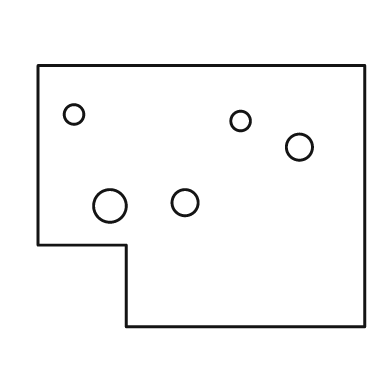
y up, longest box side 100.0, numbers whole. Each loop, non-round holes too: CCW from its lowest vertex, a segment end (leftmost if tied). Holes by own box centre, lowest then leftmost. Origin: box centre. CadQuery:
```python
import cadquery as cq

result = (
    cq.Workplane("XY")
    .moveTo(-23.0, -40.0)
    .lineTo(50.0, -40.0)
    .lineTo(50.0, 40.0)
    .lineTo(-50.0, 40.0)
    .lineTo(-50.0, -15.0)
    .lineTo(-23.0, -15.0)
    .close()
    .moveTo(-28.0, -3.0)
    .circle(5.0)
    .moveTo(-5.0, -2.0)
    .circle(4.0)
    .moveTo(30.0, 15.0)
    .circle(4.0)
    .moveTo(12.0, 23.0)
    .circle(3.0)
    .moveTo(-39.0, 25.0)
    .circle(3.0)
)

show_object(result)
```